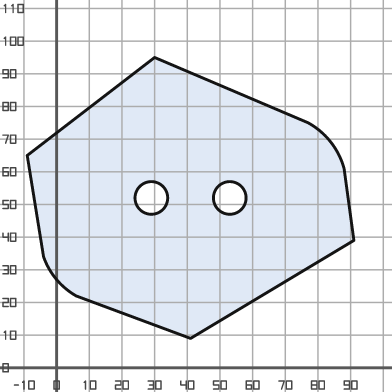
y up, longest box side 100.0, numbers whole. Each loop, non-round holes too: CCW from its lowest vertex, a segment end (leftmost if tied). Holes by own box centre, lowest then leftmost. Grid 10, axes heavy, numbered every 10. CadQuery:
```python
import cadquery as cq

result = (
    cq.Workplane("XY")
    .moveTo(41.0, 9.0)
    .lineTo(91.0, 39.0)
    .lineTo(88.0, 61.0)
    .threePointArc((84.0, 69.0), (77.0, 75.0))
    .lineTo(30.0, 95.0)
    .lineTo(-9.0, 65.0)
    .lineTo(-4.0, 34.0)
    .threePointArc((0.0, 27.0), (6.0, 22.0))
    .close()
    .moveTo(29.0, 52.0)
    .circle(5.0)
    .moveTo(53.0, 52.0)
    .circle(5.0)
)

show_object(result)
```